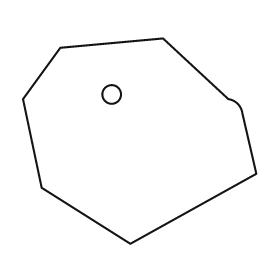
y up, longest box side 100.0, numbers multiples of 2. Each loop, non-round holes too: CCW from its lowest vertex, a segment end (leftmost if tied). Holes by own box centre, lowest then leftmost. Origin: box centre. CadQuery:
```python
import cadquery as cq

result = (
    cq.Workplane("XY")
    .moveTo(-4.0, -44.0)
    .lineTo(50.0, -14.0)
    .lineTo(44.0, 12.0)
    .threePointArc((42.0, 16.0), (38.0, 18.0))
    .lineTo(10.0, 44.0)
    .lineTo(-34.0, 40.0)
    .lineTo(-50.0, 18.0)
    .lineTo(-42.0, -20.0)
    .close()
    .moveTo(-12.0, 20.0)
    .circle(4.0)
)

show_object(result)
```